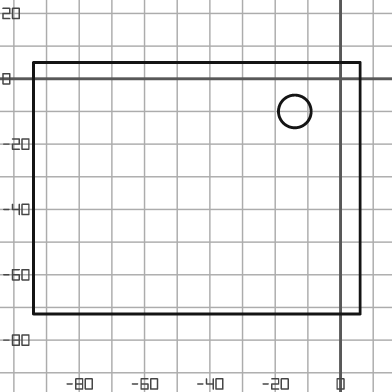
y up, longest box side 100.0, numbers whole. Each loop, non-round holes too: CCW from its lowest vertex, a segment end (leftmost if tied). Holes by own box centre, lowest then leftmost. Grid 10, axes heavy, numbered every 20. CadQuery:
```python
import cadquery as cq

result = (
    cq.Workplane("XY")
    .moveTo(-94.0, -72.0)
    .lineTo(6.0, -72.0)
    .lineTo(6.0, 5.0)
    .lineTo(-94.0, 5.0)
    .close()
    .moveTo(-14.0, -10.0)
    .circle(5.0)
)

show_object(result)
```